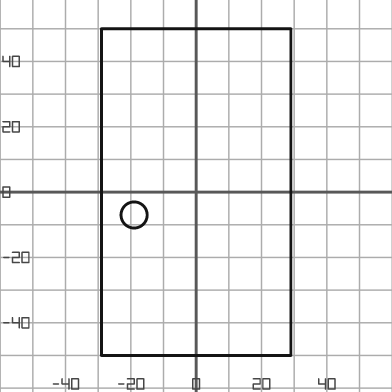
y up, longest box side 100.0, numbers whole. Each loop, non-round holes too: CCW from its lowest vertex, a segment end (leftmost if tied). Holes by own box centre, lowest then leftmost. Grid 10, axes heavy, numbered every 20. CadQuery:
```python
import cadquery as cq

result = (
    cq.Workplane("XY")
    .moveTo(-29.0, -50.0)
    .lineTo(29.0, -50.0)
    .lineTo(29.0, 50.0)
    .lineTo(-29.0, 50.0)
    .close()
    .moveTo(-19.0, -7.0)
    .circle(4.0)
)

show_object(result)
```